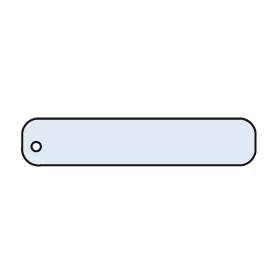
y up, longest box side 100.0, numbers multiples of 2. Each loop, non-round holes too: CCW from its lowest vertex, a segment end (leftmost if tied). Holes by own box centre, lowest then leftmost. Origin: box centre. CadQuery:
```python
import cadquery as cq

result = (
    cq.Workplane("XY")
    .moveTo(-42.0, -10.0)
    .lineTo(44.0, -10.0)
    .threePointArc((48.0, -8.0), (50.0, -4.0))
    .lineTo(50.0, 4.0)
    .threePointArc((48.0, 8.0), (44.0, 10.0))
    .lineTo(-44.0, 10.0)
    .threePointArc((-48.0, 8.0), (-50.0, 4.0))
    .lineTo(-50.0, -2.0)
    .threePointArc((-48.0, -8.0), (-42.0, -10.0))
    .close()
    .moveTo(-44.0, -2.0)
    .circle(2.0)
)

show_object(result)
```